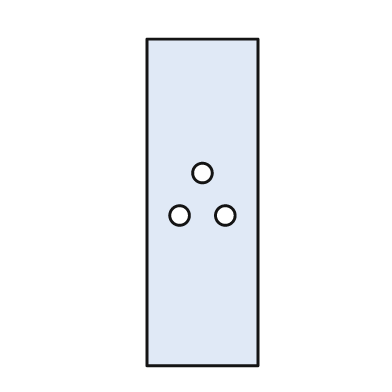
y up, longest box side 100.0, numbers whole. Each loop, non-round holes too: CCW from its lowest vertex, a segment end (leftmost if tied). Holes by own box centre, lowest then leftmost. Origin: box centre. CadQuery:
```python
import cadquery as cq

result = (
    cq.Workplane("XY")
    .moveTo(-17.0, -50.0)
    .lineTo(17.0, -50.0)
    .lineTo(17.0, 50.0)
    .lineTo(-17.0, 50.0)
    .close()
    .moveTo(-7.0, -4.0)
    .circle(3.0)
    .moveTo(7.0, -4.0)
    .circle(3.0)
    .moveTo(0.0, 9.0)
    .circle(3.0)
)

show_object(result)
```